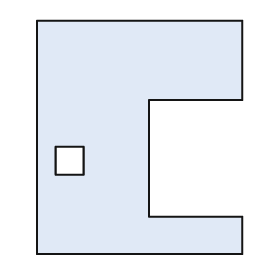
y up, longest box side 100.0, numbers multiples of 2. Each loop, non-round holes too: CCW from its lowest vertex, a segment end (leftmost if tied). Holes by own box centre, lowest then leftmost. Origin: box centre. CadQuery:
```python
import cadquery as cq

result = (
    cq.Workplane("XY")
    .moveTo(-44.0, -50.0)
    .lineTo(44.0, -50.0)
    .lineTo(44.0, -34.0)
    .lineTo(4.0, -34.0)
    .lineTo(4.0, 16.0)
    .lineTo(44.0, 16.0)
    .lineTo(44.0, 50.0)
    .lineTo(-44.0, 50.0)
    .close()
    .moveTo(-36.0, -16.0)
    .lineTo(-24.0, -16.0)
    .lineTo(-24.0, -4.0)
    .lineTo(-36.0, -4.0)
    .close()
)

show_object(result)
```